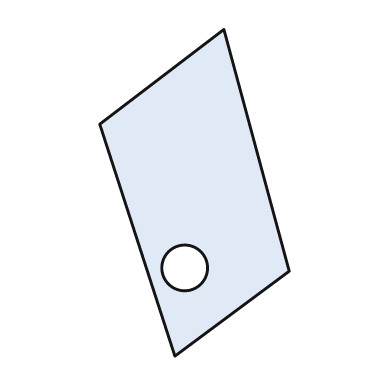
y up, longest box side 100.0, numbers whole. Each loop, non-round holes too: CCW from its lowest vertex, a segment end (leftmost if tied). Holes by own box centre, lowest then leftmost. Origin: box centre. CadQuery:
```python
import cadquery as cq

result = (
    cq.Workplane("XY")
    .moveTo(-6.0, -50.0)
    .lineTo(29.0, -24.0)
    .lineTo(9.0, 50.0)
    .lineTo(-29.0, 21.0)
    .close()
    .moveTo(-3.0, -23.0)
    .circle(7.0)
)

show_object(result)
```